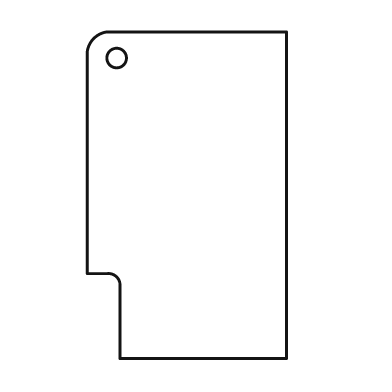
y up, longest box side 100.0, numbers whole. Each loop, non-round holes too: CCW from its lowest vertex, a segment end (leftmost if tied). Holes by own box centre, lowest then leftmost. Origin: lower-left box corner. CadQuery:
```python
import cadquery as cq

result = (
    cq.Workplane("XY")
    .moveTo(10.0, 0.0)
    .lineTo(61.0, 0.0)
    .lineTo(61.0, 100.0)
    .lineTo(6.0, 100.0)
    .threePointArc((2.0, 98.0), (0.0, 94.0))
    .lineTo(0.0, 26.0)
    .lineTo(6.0, 26.0)
    .threePointArc((9.0, 25.0), (10.0, 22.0))
    .close()
    .moveTo(9.0, 92.0)
    .circle(3.0)
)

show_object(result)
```